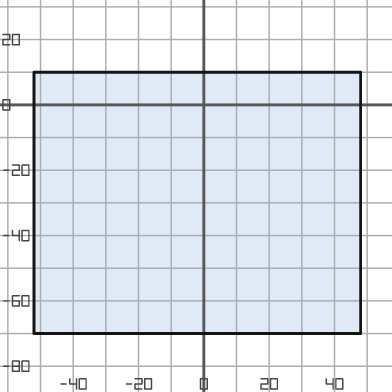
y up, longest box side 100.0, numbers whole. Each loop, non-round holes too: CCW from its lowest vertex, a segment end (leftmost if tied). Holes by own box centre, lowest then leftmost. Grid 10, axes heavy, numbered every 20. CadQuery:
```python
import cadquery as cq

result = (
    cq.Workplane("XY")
    .moveTo(-52.0, -70.0)
    .lineTo(48.0, -70.0)
    .lineTo(48.0, 10.0)
    .lineTo(-52.0, 10.0)
    .close()
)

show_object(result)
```